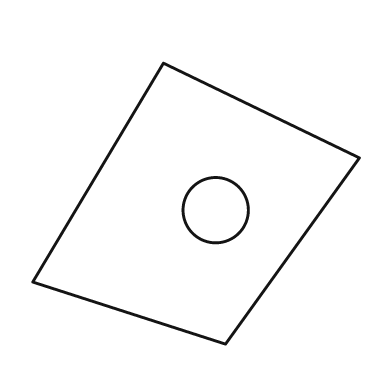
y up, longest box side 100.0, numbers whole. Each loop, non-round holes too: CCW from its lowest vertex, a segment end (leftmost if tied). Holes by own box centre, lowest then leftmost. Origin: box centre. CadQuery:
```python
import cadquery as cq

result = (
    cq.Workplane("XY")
    .moveTo(9.0, -43.0)
    .lineTo(50.0, 14.0)
    .lineTo(-10.0, 43.0)
    .lineTo(-50.0, -24.0)
    .close()
    .moveTo(6.0, -2.0)
    .circle(10.0)
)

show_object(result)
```